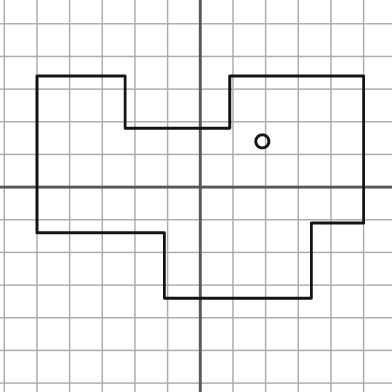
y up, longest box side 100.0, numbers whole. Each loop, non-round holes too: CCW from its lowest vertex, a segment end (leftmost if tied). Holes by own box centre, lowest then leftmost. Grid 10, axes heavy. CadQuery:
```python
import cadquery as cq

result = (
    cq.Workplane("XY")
    .moveTo(-11.0, -34.0)
    .lineTo(34.0, -34.0)
    .lineTo(34.0, -11.0)
    .lineTo(50.0, -11.0)
    .lineTo(50.0, 34.0)
    .lineTo(9.0, 34.0)
    .lineTo(9.0, 18.0)
    .lineTo(-23.0, 18.0)
    .lineTo(-23.0, 34.0)
    .lineTo(-50.0, 34.0)
    .lineTo(-50.0, -14.0)
    .lineTo(-11.0, -14.0)
    .close()
    .moveTo(19.0, 14.0)
    .circle(2.0)
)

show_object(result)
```